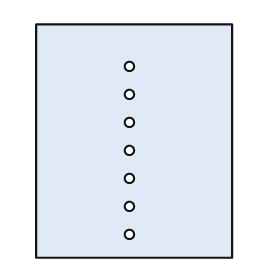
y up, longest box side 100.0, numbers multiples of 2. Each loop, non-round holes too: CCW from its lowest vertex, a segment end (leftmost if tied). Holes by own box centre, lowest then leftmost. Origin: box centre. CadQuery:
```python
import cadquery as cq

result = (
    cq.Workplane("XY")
    .moveTo(-42.0, -50.0)
    .lineTo(42.0, -50.0)
    .lineTo(42.0, 50.0)
    .lineTo(-42.0, 50.0)
    .close()
    .moveTo(-2.0, -40.0)
    .circle(2.0)
    .moveTo(-2.0, -28.0)
    .circle(2.0)
    .moveTo(-2.0, -16.0)
    .circle(2.0)
    .moveTo(-2.0, -4.0)
    .circle(2.0)
    .moveTo(-2.0, 8.0)
    .circle(2.0)
    .moveTo(-2.0, 20.0)
    .circle(2.0)
    .moveTo(-2.0, 32.0)
    .circle(2.0)
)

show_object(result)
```